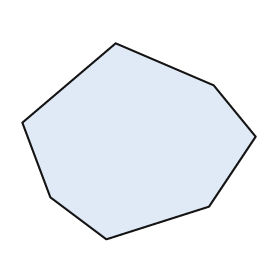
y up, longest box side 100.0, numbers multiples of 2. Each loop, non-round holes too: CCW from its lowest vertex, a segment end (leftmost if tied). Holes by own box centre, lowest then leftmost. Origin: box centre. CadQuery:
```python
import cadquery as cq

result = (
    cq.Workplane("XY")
    .moveTo(-14.0, -42.0)
    .lineTo(30.0, -28.0)
    .lineTo(50.0, 2.0)
    .lineTo(32.0, 24.0)
    .lineTo(-10.0, 42.0)
    .lineTo(-50.0, 8.0)
    .lineTo(-38.0, -24.0)
    .close()
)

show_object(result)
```